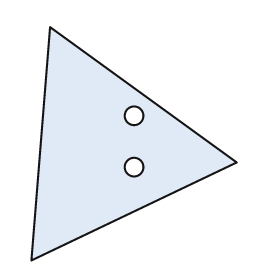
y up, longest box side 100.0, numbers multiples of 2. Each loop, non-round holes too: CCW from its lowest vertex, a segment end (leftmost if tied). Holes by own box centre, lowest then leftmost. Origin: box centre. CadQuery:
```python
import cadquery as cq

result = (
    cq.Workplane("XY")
    .moveTo(-44.0, -50.0)
    .lineTo(44.0, -8.0)
    .lineTo(-36.0, 50.0)
    .close()
    .moveTo(0.0, -10.0)
    .circle(4.0)
    .moveTo(0.0, 12.0)
    .circle(4.0)
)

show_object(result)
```